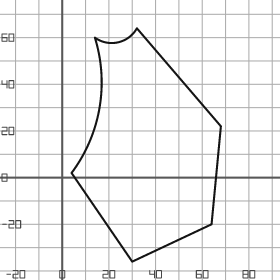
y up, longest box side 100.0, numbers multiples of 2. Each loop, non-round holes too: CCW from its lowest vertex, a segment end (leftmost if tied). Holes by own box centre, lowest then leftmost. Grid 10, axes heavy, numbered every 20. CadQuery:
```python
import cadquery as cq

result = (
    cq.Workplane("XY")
    .moveTo(30.0, -36.0)
    .lineTo(64.0, -20.0)
    .lineTo(68.0, 22.0)
    .lineTo(32.0, 64.0)
    .threePointArc((24.0, 58.0), (14.0, 60.0))
    .threePointArc((16.0, 30.0), (4.0, 2.0))
    .close()
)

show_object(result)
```